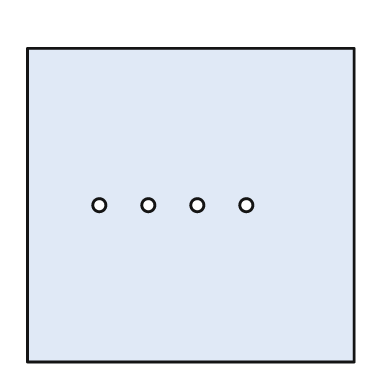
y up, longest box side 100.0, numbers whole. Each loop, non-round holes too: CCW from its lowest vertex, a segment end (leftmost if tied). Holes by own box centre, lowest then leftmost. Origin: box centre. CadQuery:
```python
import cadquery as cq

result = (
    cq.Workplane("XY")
    .moveTo(-50.0, -48.0)
    .lineTo(50.0, -48.0)
    .lineTo(50.0, 48.0)
    .lineTo(-50.0, 48.0)
    .close()
    .moveTo(-28.0, 0.0)
    .circle(2.0)
    .moveTo(-13.0, 0.0)
    .circle(2.0)
    .moveTo(2.0, 0.0)
    .circle(2.0)
    .moveTo(17.0, 0.0)
    .circle(2.0)
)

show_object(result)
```